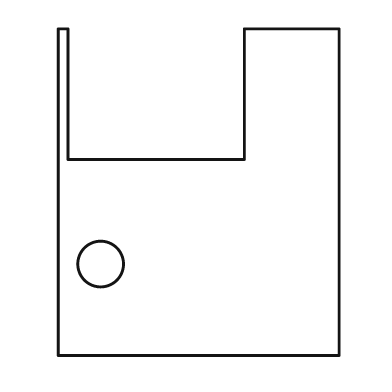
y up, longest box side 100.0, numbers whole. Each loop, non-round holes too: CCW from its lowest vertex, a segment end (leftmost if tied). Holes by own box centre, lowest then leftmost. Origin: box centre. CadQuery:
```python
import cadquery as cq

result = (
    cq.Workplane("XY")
    .moveTo(-43.0, -50.0)
    .lineTo(43.0, -50.0)
    .lineTo(43.0, 50.0)
    .lineTo(14.0, 50.0)
    .lineTo(14.0, 10.0)
    .lineTo(-40.0, 10.0)
    .lineTo(-40.0, 50.0)
    .lineTo(-43.0, 50.0)
    .close()
    .moveTo(-30.0, -22.0)
    .circle(7.0)
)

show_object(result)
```